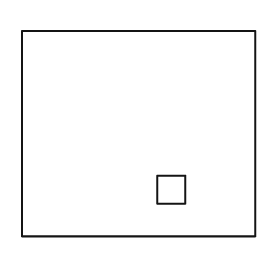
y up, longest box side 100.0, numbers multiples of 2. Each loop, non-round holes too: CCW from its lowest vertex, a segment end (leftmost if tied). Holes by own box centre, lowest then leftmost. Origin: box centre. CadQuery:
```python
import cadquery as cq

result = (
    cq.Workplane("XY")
    .moveTo(-50.0, -44.0)
    .lineTo(50.0, -44.0)
    .lineTo(50.0, 44.0)
    .lineTo(-50.0, 44.0)
    .close()
    .moveTo(8.0, -30.0)
    .lineTo(20.0, -30.0)
    .lineTo(20.0, -18.0)
    .lineTo(8.0, -18.0)
    .close()
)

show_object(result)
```